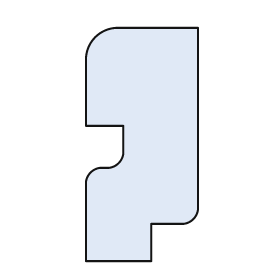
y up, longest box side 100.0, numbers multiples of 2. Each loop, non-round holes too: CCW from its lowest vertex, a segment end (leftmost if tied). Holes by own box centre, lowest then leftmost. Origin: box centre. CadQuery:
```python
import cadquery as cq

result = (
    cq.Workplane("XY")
    .moveTo(-24.0, -50.0)
    .lineTo(4.0, -50.0)
    .lineTo(4.0, -34.0)
    .lineTo(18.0, -34.0)
    .threePointArc((22.0, -32.0), (24.0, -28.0))
    .lineTo(24.0, 50.0)
    .lineTo(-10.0, 50.0)
    .threePointArc((-20.0, 46.0), (-24.0, 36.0))
    .lineTo(-24.0, 8.0)
    .lineTo(-8.0, 8.0)
    .lineTo(-8.0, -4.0)
    .threePointArc((-10.0, -8.0), (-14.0, -10.0))
    .lineTo(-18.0, -10.0)
    .threePointArc((-22.0, -12.0), (-24.0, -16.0))
    .close()
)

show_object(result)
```